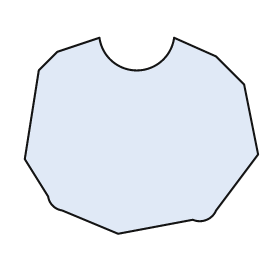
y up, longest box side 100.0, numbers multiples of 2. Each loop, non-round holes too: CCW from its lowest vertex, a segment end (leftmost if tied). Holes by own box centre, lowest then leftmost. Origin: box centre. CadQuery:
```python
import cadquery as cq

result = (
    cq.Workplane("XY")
    .moveTo(-10.0, -42.0)
    .lineTo(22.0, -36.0)
    .threePointArc((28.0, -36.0), (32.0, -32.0))
    .lineTo(50.0, -8.0)
    .lineTo(44.0, 22.0)
    .lineTo(32.0, 34.0)
    .lineTo(14.0, 42.0)
    .threePointArc((-2.0, 28.0), (-18.0, 42.0))
    .lineTo(-36.0, 36.0)
    .lineTo(-44.0, 28.0)
    .lineTo(-50.0, -10.0)
    .lineTo(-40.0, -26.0)
    .threePointArc((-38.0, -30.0), (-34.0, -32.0))
    .close()
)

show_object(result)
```